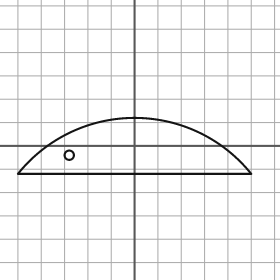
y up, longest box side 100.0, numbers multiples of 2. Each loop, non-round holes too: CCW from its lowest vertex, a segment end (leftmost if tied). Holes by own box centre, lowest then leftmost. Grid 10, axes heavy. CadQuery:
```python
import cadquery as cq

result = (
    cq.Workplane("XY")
    .moveTo(-50.0, -12.0)
    .lineTo(50.0, -12.0)
    .threePointArc((0.0, 12.0), (-50.0, -12.0))
    .close()
    .moveTo(-28.0, -4.0)
    .circle(2.0)
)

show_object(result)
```